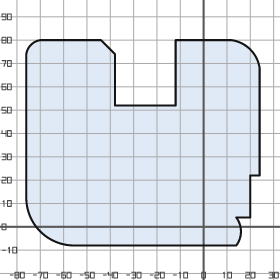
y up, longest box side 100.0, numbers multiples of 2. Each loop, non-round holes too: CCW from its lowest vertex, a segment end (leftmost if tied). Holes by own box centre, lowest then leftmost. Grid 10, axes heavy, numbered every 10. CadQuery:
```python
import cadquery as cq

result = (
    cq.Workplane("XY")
    .moveTo(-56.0, -8.0)
    .lineTo(14.0, -8.0)
    .threePointArc((16.0, -2.0), (14.0, 4.0))
    .lineTo(20.0, 4.0)
    .lineTo(20.0, 22.0)
    .lineTo(24.0, 22.0)
    .lineTo(24.0, 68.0)
    .threePointArc((20.0, 76.0), (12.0, 80.0))
    .lineTo(-12.0, 80.0)
    .lineTo(-12.0, 52.0)
    .lineTo(-38.0, 52.0)
    .lineTo(-38.0, 74.0)
    .lineTo(-44.0, 80.0)
    .lineTo(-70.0, 80.0)
    .threePointArc((-74.0, 78.0), (-76.0, 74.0))
    .lineTo(-76.0, 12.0)
    .threePointArc((-70.0, -2.0), (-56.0, -8.0))
    .close()
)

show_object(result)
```